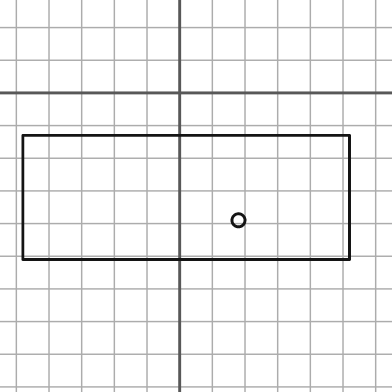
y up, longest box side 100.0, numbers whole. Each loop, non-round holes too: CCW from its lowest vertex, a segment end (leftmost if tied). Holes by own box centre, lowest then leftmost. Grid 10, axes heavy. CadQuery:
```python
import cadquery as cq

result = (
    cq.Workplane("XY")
    .moveTo(-48.0, -51.0)
    .lineTo(52.0, -51.0)
    .lineTo(52.0, -13.0)
    .lineTo(-48.0, -13.0)
    .close()
    .moveTo(18.0, -39.0)
    .circle(2.0)
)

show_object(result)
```